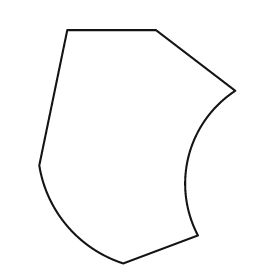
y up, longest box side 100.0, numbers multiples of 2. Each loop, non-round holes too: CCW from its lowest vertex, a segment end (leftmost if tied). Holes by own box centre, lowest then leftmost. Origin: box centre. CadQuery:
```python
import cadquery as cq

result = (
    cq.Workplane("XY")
    .moveTo(-6.0, -50.0)
    .lineTo(26.0, -38.0)
    .threePointArc((22.0, -4.0), (42.0, 24.0))
    .lineTo(8.0, 50.0)
    .lineTo(-30.0, 50.0)
    .lineTo(-42.0, -8.0)
    .threePointArc((-30.0, -34.0), (-6.0, -50.0))
    .close()
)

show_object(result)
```